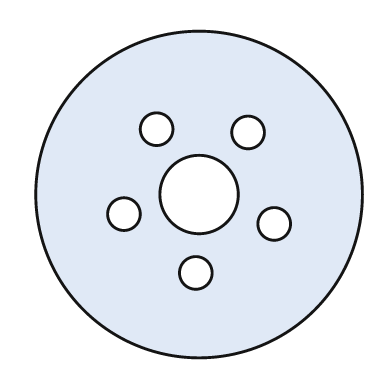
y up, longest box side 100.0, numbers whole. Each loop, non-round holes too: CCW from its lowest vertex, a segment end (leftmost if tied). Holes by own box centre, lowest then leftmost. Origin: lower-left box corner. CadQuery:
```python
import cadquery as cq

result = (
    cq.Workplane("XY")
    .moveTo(50.0, 50.0)
    .circle(50.0)
    .moveTo(49.0, 26.0)
    .circle(5.0)
    .moveTo(73.0, 41.0)
    .circle(5.0)
    .moveTo(27.0, 44.0)
    .circle(5.0)
    .moveTo(50.0, 50.0)
    .circle(12.0)
    .moveTo(65.0, 69.0)
    .circle(5.0)
    .moveTo(37.0, 70.0)
    .circle(5.0)
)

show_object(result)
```